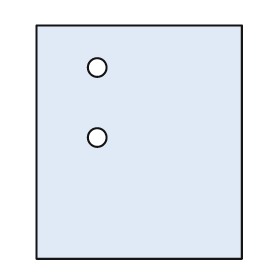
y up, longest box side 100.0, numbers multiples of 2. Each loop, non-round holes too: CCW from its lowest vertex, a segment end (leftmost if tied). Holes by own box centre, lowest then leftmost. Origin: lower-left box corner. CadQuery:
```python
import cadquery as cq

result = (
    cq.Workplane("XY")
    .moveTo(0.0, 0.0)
    .lineTo(88.0, 0.0)
    .lineTo(88.0, 100.0)
    .lineTo(0.0, 100.0)
    .close()
    .moveTo(26.0, 52.0)
    .circle(4.0)
    .moveTo(26.0, 82.0)
    .circle(4.0)
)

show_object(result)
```